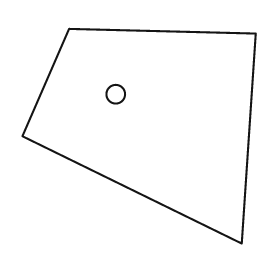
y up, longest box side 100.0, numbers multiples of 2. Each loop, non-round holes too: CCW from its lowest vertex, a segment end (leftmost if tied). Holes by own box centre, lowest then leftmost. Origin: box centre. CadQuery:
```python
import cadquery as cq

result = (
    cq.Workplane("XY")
    .moveTo(44.0, -46.0)
    .lineTo(50.0, 44.0)
    .lineTo(-30.0, 46.0)
    .lineTo(-50.0, 0.0)
    .close()
    .moveTo(-10.0, 18.0)
    .circle(4.0)
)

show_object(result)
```